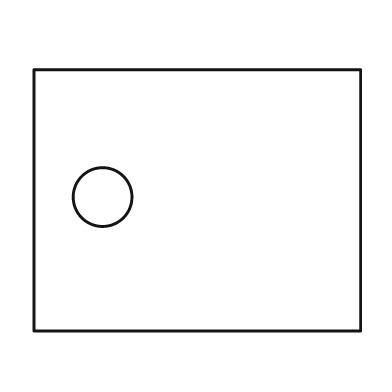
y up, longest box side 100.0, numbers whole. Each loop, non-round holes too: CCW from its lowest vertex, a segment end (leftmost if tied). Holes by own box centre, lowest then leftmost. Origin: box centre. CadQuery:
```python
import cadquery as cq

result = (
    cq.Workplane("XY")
    .moveTo(-50.0, -40.0)
    .lineTo(50.0, -40.0)
    .lineTo(50.0, 40.0)
    .lineTo(-50.0, 40.0)
    .close()
    .moveTo(-29.0, 1.0)
    .circle(9.0)
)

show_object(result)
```